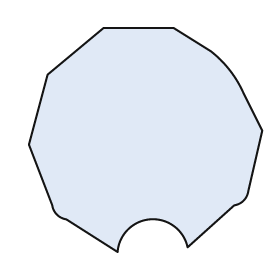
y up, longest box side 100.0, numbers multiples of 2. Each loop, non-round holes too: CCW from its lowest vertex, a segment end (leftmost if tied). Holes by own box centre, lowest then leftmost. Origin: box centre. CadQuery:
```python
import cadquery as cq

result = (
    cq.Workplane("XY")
    .moveTo(-12.0, -48.0)
    .threePointArc((2.0, -34.0), (18.0, -46.0))
    .lineTo(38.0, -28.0)
    .threePointArc((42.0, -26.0), (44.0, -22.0))
    .lineTo(50.0, 4.0)
    .lineTo(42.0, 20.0)
    .threePointArc((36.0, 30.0), (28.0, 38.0))
    .lineTo(12.0, 48.0)
    .lineTo(-18.0, 48.0)
    .lineTo(-42.0, 28.0)
    .lineTo(-50.0, -2.0)
    .lineTo(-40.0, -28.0)
    .threePointArc((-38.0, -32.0), (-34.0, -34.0))
    .close()
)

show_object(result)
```